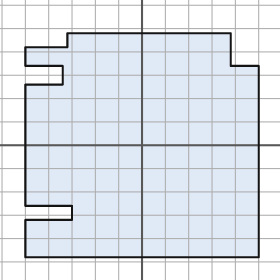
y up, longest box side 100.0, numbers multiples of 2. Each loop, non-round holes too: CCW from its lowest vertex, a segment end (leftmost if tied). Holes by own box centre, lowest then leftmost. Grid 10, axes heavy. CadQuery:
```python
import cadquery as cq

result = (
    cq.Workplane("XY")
    .moveTo(-50.0, -48.0)
    .lineTo(50.0, -48.0)
    .lineTo(50.0, 34.0)
    .lineTo(38.0, 34.0)
    .lineTo(38.0, 48.0)
    .lineTo(-32.0, 48.0)
    .lineTo(-32.0, 42.0)
    .lineTo(-50.0, 42.0)
    .lineTo(-50.0, 34.0)
    .lineTo(-34.0, 34.0)
    .lineTo(-34.0, 26.0)
    .lineTo(-50.0, 26.0)
    .lineTo(-50.0, -26.0)
    .lineTo(-30.0, -26.0)
    .lineTo(-30.0, -32.0)
    .lineTo(-50.0, -32.0)
    .close()
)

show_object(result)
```